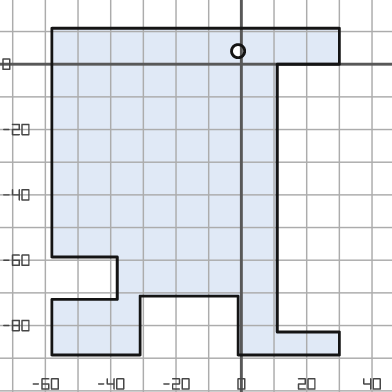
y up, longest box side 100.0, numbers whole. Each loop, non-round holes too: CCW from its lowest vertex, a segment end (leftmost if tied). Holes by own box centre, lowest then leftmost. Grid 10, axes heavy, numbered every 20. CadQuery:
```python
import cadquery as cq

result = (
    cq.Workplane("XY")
    .moveTo(-58.0, -89.0)
    .lineTo(-31.0, -89.0)
    .lineTo(-31.0, -71.0)
    .lineTo(-1.0, -71.0)
    .lineTo(-1.0, -89.0)
    .lineTo(30.0, -89.0)
    .lineTo(30.0, -82.0)
    .lineTo(11.0, -82.0)
    .lineTo(11.0, 0.0)
    .lineTo(30.0, 0.0)
    .lineTo(30.0, 11.0)
    .lineTo(-58.0, 11.0)
    .lineTo(-58.0, -59.0)
    .lineTo(-38.0, -59.0)
    .lineTo(-38.0, -72.0)
    .lineTo(-58.0, -72.0)
    .close()
    .moveTo(-1.0, 4.0)
    .circle(2.0)
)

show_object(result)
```